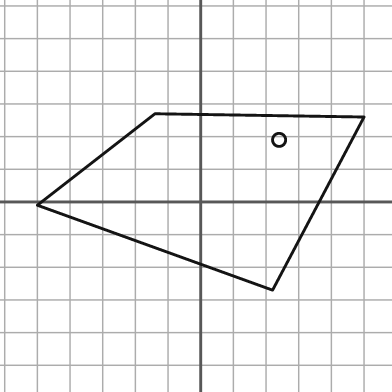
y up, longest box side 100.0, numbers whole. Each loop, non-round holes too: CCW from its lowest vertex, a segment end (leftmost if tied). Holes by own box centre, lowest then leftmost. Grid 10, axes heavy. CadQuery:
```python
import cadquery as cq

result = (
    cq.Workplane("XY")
    .moveTo(22.0, -27.0)
    .lineTo(50.0, 26.0)
    .lineTo(-14.0, 27.0)
    .lineTo(-50.0, -1.0)
    .close()
    .moveTo(24.0, 19.0)
    .circle(2.0)
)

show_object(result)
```